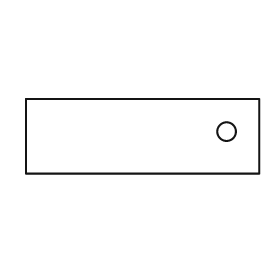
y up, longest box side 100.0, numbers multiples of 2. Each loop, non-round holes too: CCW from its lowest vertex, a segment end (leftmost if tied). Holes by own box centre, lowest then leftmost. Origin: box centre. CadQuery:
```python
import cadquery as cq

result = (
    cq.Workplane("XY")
    .moveTo(-50.0, -16.0)
    .lineTo(50.0, -16.0)
    .lineTo(50.0, 16.0)
    .lineTo(-50.0, 16.0)
    .close()
    .moveTo(36.0, 2.0)
    .circle(4.0)
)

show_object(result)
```